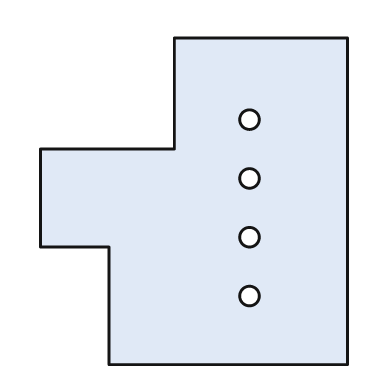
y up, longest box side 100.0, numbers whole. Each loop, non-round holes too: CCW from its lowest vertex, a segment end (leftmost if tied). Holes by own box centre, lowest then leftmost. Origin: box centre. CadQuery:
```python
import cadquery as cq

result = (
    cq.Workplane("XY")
    .moveTo(-26.0, -50.0)
    .lineTo(47.0, -50.0)
    .lineTo(47.0, 50.0)
    .lineTo(-6.0, 50.0)
    .lineTo(-6.0, 16.0)
    .lineTo(-47.0, 16.0)
    .lineTo(-47.0, -14.0)
    .lineTo(-26.0, -14.0)
    .close()
    .moveTo(17.0, -29.0)
    .circle(3.0)
    .moveTo(17.0, -11.0)
    .circle(3.0)
    .moveTo(17.0, 7.0)
    .circle(3.0)
    .moveTo(17.0, 25.0)
    .circle(3.0)
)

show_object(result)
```